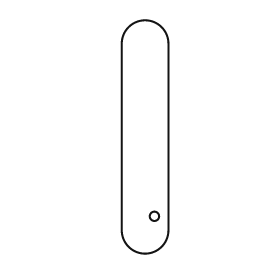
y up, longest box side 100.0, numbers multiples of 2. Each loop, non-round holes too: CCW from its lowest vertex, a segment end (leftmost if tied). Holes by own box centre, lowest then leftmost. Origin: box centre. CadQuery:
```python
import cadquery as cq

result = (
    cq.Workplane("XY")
    .moveTo(-10.0, -40.0)
    .threePointArc((0.0, -50.0), (10.0, -40.0))
    .lineTo(10.0, 40.0)
    .threePointArc((0.0, 50.0), (-10.0, 40.0))
    .close()
    .moveTo(4.0, -34.0)
    .circle(2.0)
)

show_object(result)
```